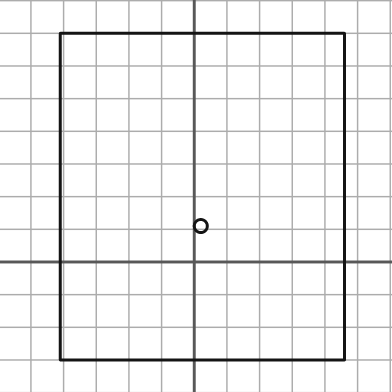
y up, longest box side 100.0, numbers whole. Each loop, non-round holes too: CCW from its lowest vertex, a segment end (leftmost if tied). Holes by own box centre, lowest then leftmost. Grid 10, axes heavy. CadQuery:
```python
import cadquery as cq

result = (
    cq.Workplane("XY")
    .moveTo(-41.0, -30.0)
    .lineTo(46.0, -30.0)
    .lineTo(46.0, 70.0)
    .lineTo(-41.0, 70.0)
    .close()
    .moveTo(2.0, 11.0)
    .circle(2.0)
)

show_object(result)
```